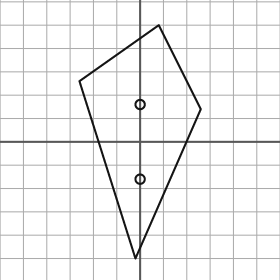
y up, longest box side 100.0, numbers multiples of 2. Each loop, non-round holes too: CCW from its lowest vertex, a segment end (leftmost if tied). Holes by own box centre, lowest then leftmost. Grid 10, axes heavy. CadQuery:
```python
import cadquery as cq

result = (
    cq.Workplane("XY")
    .moveTo(-2.0, -50.0)
    .lineTo(26.0, 14.0)
    .lineTo(8.0, 50.0)
    .lineTo(-26.0, 26.0)
    .close()
    .moveTo(0.0, -16.0)
    .circle(2.0)
    .moveTo(0.0, 16.0)
    .circle(2.0)
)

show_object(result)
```